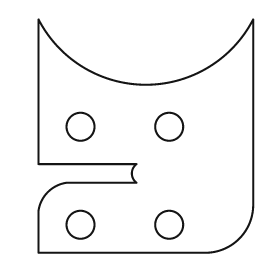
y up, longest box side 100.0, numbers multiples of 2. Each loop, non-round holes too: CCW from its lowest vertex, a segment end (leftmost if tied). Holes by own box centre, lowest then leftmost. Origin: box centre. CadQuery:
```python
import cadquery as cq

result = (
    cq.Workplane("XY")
    .moveTo(-46.0, -50.0)
    .lineTo(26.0, -50.0)
    .threePointArc((40.0, -44.0), (46.0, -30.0))
    .lineTo(46.0, 50.0)
    .threePointArc((0.0, 22.0), (-46.0, 50.0))
    .lineTo(-46.0, -12.0)
    .lineTo(-4.0, -12.0)
    .threePointArc((-6.0, -16.0), (-4.0, -20.0))
    .lineTo(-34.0, -20.0)
    .threePointArc((-42.0, -24.0), (-46.0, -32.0))
    .close()
    .moveTo(-28.0, -38.0)
    .circle(6.0)
    .moveTo(10.0, -38.0)
    .circle(6.0)
    .moveTo(-28.0, 4.0)
    .circle(6.0)
    .moveTo(10.0, 4.0)
    .circle(6.0)
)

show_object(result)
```